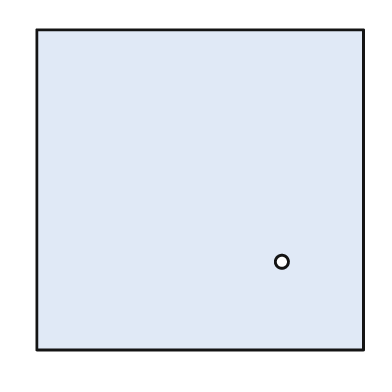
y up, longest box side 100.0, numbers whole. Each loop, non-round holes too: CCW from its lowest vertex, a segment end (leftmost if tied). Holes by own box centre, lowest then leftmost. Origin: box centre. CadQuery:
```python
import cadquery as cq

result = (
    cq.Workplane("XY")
    .moveTo(-50.0, -49.0)
    .lineTo(50.0, -49.0)
    .lineTo(50.0, 49.0)
    .lineTo(-50.0, 49.0)
    .close()
    .moveTo(25.0, -22.0)
    .circle(2.0)
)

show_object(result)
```